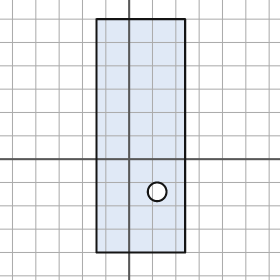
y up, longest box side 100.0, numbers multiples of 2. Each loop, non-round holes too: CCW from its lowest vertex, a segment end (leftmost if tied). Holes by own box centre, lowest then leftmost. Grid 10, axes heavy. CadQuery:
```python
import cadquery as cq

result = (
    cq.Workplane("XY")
    .moveTo(-14.0, -40.0)
    .lineTo(24.0, -40.0)
    .lineTo(24.0, 60.0)
    .lineTo(-14.0, 60.0)
    .close()
    .moveTo(12.0, -14.0)
    .circle(4.0)
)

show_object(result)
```